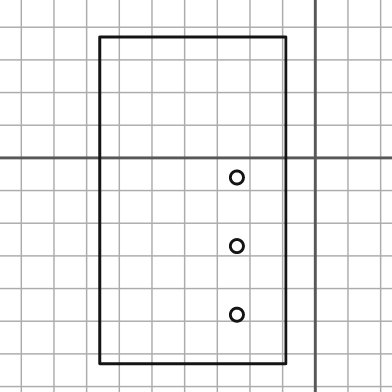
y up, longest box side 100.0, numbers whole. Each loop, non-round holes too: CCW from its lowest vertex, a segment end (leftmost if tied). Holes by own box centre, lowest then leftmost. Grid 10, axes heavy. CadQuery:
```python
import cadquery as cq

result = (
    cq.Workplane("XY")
    .moveTo(-66.0, -63.0)
    .lineTo(-9.0, -63.0)
    .lineTo(-9.0, 37.0)
    .lineTo(-66.0, 37.0)
    .close()
    .moveTo(-24.0, -48.0)
    .circle(2.0)
    .moveTo(-24.0, -27.0)
    .circle(2.0)
    .moveTo(-24.0, -6.0)
    .circle(2.0)
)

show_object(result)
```